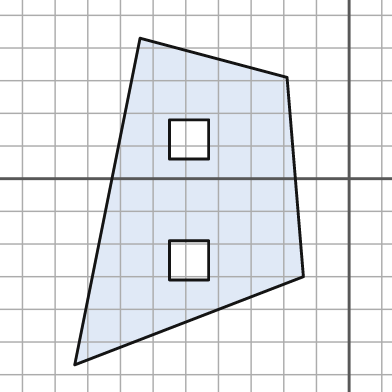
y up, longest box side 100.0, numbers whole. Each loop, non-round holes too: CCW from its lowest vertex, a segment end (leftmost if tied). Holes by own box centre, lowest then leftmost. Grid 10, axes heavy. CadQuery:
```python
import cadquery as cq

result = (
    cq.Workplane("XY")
    .moveTo(-84.0, -57.0)
    .lineTo(-14.0, -30.0)
    .lineTo(-19.0, 31.0)
    .lineTo(-64.0, 43.0)
    .close()
    .moveTo(-55.0, -31.0)
    .lineTo(-43.0, -31.0)
    .lineTo(-43.0, -19.0)
    .lineTo(-55.0, -19.0)
    .close()
    .moveTo(-55.0, 6.0)
    .lineTo(-43.0, 6.0)
    .lineTo(-43.0, 18.0)
    .lineTo(-55.0, 18.0)
    .close()
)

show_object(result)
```